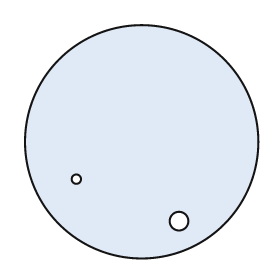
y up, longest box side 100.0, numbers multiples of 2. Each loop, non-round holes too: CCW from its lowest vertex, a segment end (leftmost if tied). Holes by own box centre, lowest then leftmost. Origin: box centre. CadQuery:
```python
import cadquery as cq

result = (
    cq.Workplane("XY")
    .moveTo(0.0, 0.0)
    .circle(50.0)
    .moveTo(16.0, -34.0)
    .circle(4.0)
    .moveTo(-28.0, -16.0)
    .circle(2.0)
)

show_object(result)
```